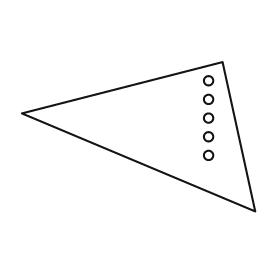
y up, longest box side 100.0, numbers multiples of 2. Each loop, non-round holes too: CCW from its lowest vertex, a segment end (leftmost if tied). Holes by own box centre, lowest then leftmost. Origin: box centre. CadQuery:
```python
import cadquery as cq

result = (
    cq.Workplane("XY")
    .moveTo(50.0, -32.0)
    .lineTo(36.0, 32.0)
    .lineTo(-50.0, 10.0)
    .close()
    .moveTo(30.0, -8.0)
    .circle(2.0)
    .moveTo(30.0, 0.0)
    .circle(2.0)
    .moveTo(30.0, 8.0)
    .circle(2.0)
    .moveTo(30.0, 16.0)
    .circle(2.0)
    .moveTo(30.0, 24.0)
    .circle(2.0)
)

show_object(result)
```